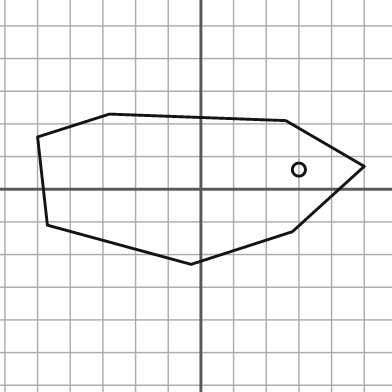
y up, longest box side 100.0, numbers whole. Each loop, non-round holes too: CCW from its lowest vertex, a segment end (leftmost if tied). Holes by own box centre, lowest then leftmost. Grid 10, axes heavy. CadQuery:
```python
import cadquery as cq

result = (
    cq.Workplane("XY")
    .moveTo(-3.0, -23.0)
    .lineTo(28.0, -13.0)
    .lineTo(50.0, 7.0)
    .lineTo(26.0, 21.0)
    .lineTo(-28.0, 23.0)
    .lineTo(-50.0, 16.0)
    .lineTo(-47.0, -11.0)
    .close()
    .moveTo(30.0, 6.0)
    .circle(2.0)
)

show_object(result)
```